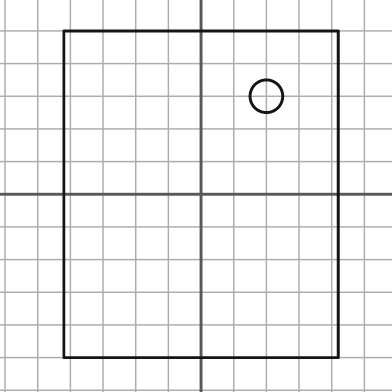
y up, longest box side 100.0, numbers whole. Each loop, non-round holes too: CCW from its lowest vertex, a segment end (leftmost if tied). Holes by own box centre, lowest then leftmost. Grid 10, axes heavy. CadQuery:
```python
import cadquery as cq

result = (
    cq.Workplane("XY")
    .moveTo(-42.0, -50.0)
    .lineTo(42.0, -50.0)
    .lineTo(42.0, 50.0)
    .lineTo(-42.0, 50.0)
    .close()
    .moveTo(20.0, 30.0)
    .circle(5.0)
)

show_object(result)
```